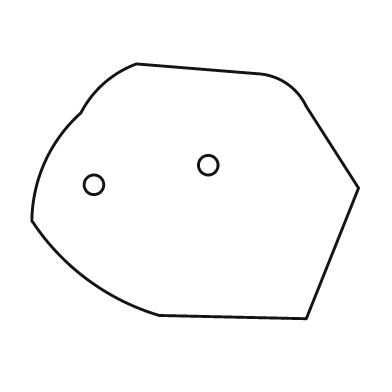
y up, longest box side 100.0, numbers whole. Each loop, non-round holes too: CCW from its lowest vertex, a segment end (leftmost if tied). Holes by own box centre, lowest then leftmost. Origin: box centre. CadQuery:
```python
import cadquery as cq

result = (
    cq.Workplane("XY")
    .moveTo(34.0, -39.0)
    .lineTo(50.0, 1.0)
    .lineTo(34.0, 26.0)
    .threePointArc((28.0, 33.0), (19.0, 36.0))
    .lineTo(-18.0, 39.0)
    .threePointArc((-28.0, 33.0), (-35.0, 24.0))
    .threePointArc((-46.0, 9.0), (-50.0, -9.0))
    .threePointArc((-33.0, -27.0), (-11.0, -38.0))
    .close()
    .moveTo(-31.0, 2.0)
    .circle(3.0)
    .moveTo(4.0, 8.0)
    .circle(3.0)
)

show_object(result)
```